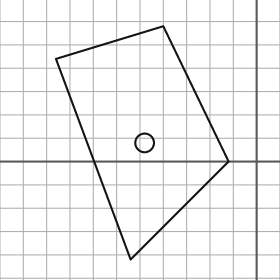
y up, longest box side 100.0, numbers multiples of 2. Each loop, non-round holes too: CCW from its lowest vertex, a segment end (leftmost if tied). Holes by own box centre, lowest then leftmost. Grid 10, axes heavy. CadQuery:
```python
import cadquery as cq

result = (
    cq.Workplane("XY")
    .moveTo(-54.0, -42.0)
    .lineTo(-12.0, 0.0)
    .lineTo(-40.0, 58.0)
    .lineTo(-86.0, 44.0)
    .close()
    .moveTo(-48.0, 8.0)
    .circle(4.0)
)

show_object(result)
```